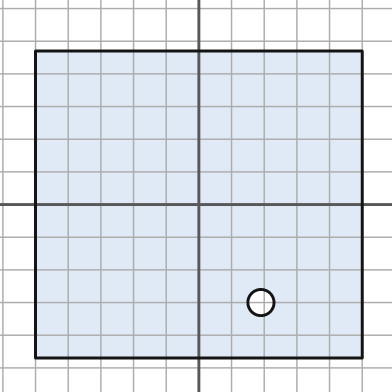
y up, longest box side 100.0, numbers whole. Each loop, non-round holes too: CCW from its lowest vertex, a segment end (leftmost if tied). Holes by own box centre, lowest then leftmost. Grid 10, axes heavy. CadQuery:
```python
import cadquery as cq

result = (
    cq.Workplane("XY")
    .moveTo(-50.0, -47.0)
    .lineTo(50.0, -47.0)
    .lineTo(50.0, 47.0)
    .lineTo(-50.0, 47.0)
    .close()
    .moveTo(19.0, -30.0)
    .circle(4.0)
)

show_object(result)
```